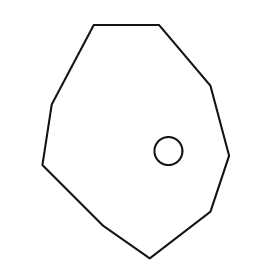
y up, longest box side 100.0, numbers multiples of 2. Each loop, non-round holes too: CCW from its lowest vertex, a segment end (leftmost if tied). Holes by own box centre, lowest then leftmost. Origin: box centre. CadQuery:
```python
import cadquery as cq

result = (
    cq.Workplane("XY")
    .moveTo(6.0, -50.0)
    .lineTo(32.0, -30.0)
    .lineTo(40.0, -6.0)
    .lineTo(32.0, 24.0)
    .lineTo(10.0, 50.0)
    .lineTo(-18.0, 50.0)
    .lineTo(-36.0, 16.0)
    .lineTo(-40.0, -10.0)
    .lineTo(-14.0, -36.0)
    .close()
    .moveTo(14.0, -4.0)
    .circle(6.0)
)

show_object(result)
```